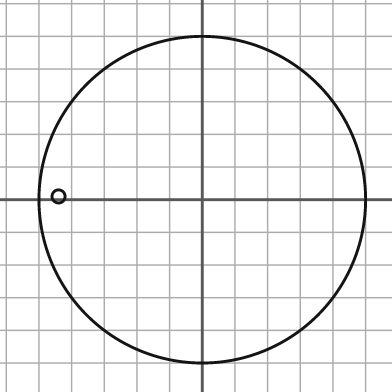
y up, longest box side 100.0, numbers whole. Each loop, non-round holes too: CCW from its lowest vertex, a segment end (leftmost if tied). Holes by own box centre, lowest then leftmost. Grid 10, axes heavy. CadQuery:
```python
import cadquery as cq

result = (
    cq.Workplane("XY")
    .moveTo(0.0, 0.0)
    .circle(50.0)
    .moveTo(-44.0, 1.0)
    .circle(2.0)
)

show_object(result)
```